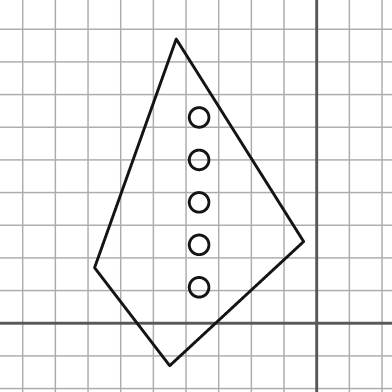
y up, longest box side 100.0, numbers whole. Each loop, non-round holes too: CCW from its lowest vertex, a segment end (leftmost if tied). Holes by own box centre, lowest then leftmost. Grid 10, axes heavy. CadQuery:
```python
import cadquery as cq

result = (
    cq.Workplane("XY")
    .moveTo(-45.0, -13.0)
    .lineTo(-4.0, 25.0)
    .lineTo(-43.0, 87.0)
    .lineTo(-68.0, 17.0)
    .close()
    .moveTo(-36.0, 11.0)
    .circle(3.0)
    .moveTo(-36.0, 24.0)
    .circle(3.0)
    .moveTo(-36.0, 37.0)
    .circle(3.0)
    .moveTo(-36.0, 50.0)
    .circle(3.0)
    .moveTo(-36.0, 63.0)
    .circle(3.0)
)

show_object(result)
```